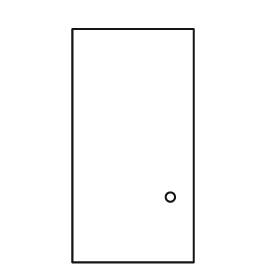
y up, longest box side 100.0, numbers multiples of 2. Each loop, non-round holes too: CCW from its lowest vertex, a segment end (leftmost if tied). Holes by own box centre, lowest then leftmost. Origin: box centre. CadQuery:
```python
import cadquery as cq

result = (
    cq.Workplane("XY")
    .moveTo(-26.0, -50.0)
    .lineTo(26.0, -50.0)
    .lineTo(26.0, 50.0)
    .lineTo(-26.0, 50.0)
    .close()
    .moveTo(16.0, -22.0)
    .circle(2.0)
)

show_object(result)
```